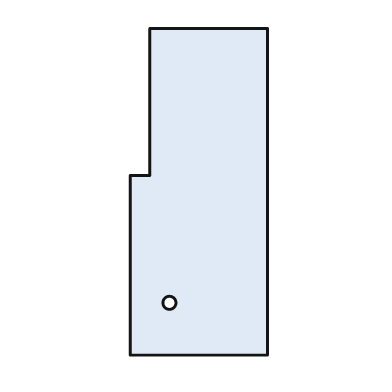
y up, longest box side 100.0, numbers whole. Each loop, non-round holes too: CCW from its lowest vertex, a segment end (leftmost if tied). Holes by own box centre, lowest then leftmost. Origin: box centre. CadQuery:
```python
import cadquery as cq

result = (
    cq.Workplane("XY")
    .moveTo(-21.0, -50.0)
    .lineTo(21.0, -50.0)
    .lineTo(21.0, 50.0)
    .lineTo(-15.0, 50.0)
    .lineTo(-15.0, 5.0)
    .lineTo(-21.0, 5.0)
    .close()
    .moveTo(-9.0, -34.0)
    .circle(2.0)
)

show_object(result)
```